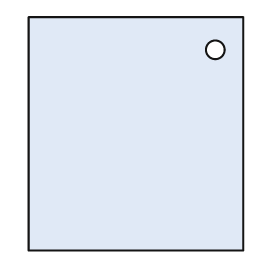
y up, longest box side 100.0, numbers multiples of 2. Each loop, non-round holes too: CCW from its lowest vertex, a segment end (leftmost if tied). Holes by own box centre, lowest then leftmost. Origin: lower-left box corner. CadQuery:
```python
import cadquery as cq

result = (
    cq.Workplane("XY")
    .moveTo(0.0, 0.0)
    .lineTo(92.0, 0.0)
    .lineTo(92.0, 100.0)
    .lineTo(0.0, 100.0)
    .close()
    .moveTo(80.0, 86.0)
    .circle(4.0)
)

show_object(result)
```